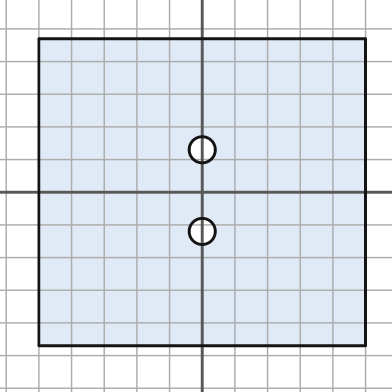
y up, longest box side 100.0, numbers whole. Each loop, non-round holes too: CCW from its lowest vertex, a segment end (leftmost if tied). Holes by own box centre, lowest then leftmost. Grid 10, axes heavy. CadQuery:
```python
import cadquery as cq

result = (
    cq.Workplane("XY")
    .moveTo(-50.0, -47.0)
    .lineTo(50.0, -47.0)
    .lineTo(50.0, 47.0)
    .lineTo(-50.0, 47.0)
    .close()
    .moveTo(0.0, -12.0)
    .circle(4.0)
    .moveTo(0.0, 13.0)
    .circle(4.0)
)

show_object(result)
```